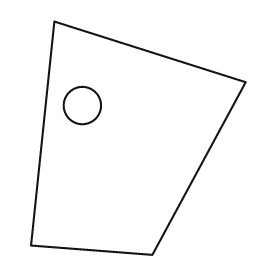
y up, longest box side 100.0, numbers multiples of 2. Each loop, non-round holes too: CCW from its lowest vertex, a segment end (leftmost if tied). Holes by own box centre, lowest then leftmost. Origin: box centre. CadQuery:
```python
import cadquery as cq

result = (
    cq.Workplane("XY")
    .moveTo(6.0, -50.0)
    .lineTo(46.0, 24.0)
    .lineTo(-36.0, 50.0)
    .lineTo(-46.0, -46.0)
    .close()
    .moveTo(-24.0, 14.0)
    .circle(8.0)
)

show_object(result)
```